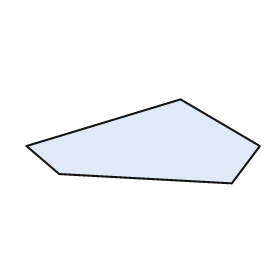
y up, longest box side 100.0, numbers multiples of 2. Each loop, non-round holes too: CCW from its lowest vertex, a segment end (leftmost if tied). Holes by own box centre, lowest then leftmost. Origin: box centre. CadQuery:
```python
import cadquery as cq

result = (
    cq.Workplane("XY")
    .moveTo(38.0, -18.0)
    .lineTo(50.0, -2.0)
    .lineTo(16.0, 18.0)
    .lineTo(-50.0, -2.0)
    .lineTo(-36.0, -14.0)
    .close()
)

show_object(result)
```